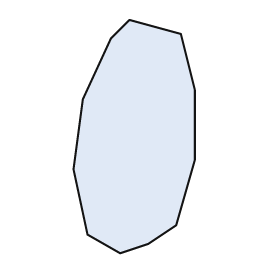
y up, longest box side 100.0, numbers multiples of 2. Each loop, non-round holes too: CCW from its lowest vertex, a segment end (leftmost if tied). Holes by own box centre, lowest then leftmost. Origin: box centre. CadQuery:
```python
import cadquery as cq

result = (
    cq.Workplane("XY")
    .moveTo(-6.0, -50.0)
    .lineTo(6.0, -46.0)
    .lineTo(18.0, -38.0)
    .lineTo(26.0, -10.0)
    .lineTo(26.0, 20.0)
    .lineTo(20.0, 44.0)
    .lineTo(-2.0, 50.0)
    .lineTo(-10.0, 42.0)
    .lineTo(-22.0, 16.0)
    .lineTo(-26.0, -14.0)
    .lineTo(-20.0, -42.0)
    .close()
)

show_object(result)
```